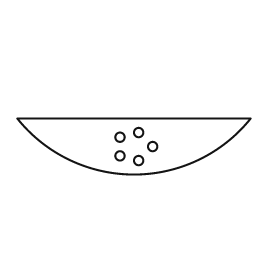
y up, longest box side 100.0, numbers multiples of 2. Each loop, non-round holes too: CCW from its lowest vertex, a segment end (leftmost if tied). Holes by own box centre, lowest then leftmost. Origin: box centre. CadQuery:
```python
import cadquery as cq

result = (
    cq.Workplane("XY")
    .moveTo(-50.0, 12.0)
    .threePointArc((0.0, -12.0), (50.0, 12.0))
    .close()
    .moveTo(2.0, -6.0)
    .circle(2.0)
    .moveTo(-6.0, -4.0)
    .circle(2.0)
    .moveTo(8.0, 0.0)
    .circle(2.0)
    .moveTo(-6.0, 4.0)
    .circle(2.0)
    .moveTo(2.0, 6.0)
    .circle(2.0)
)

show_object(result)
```